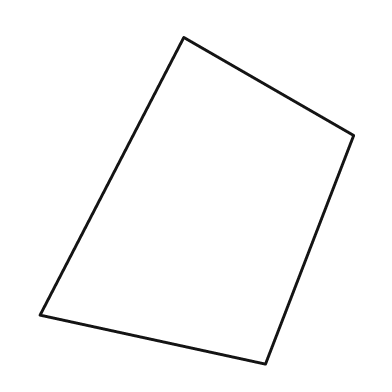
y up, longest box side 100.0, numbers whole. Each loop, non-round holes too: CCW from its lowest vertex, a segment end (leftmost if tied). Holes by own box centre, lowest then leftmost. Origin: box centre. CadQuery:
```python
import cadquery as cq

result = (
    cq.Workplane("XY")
    .moveTo(21.0, -50.0)
    .lineTo(48.0, 20.0)
    .lineTo(-4.0, 50.0)
    .lineTo(-48.0, -35.0)
    .close()
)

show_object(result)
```